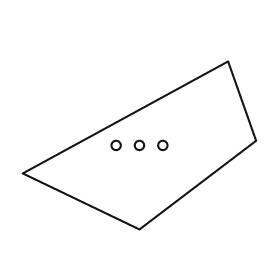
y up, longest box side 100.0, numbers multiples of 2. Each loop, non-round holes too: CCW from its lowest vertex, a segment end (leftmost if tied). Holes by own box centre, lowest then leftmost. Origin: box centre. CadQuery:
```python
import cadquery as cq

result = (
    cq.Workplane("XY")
    .moveTo(0.0, -36.0)
    .lineTo(50.0, 2.0)
    .lineTo(38.0, 36.0)
    .lineTo(-50.0, -12.0)
    .close()
    .moveTo(-10.0, 0.0)
    .circle(2.0)
    .moveTo(0.0, 0.0)
    .circle(2.0)
    .moveTo(10.0, 0.0)
    .circle(2.0)
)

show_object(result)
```